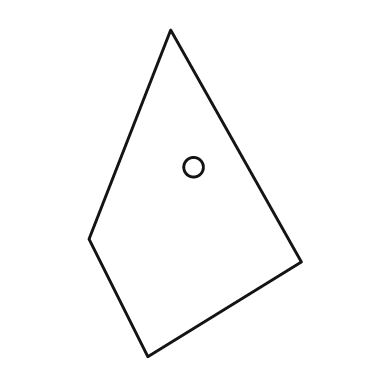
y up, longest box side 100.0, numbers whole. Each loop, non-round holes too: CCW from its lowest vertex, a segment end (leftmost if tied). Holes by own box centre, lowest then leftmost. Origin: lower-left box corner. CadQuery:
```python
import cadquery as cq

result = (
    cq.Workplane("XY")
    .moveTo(18.0, 0.0)
    .lineTo(65.0, 29.0)
    .lineTo(25.0, 100.0)
    .lineTo(0.0, 36.0)
    .close()
    .moveTo(32.0, 58.0)
    .circle(3.0)
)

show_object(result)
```